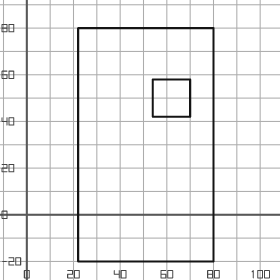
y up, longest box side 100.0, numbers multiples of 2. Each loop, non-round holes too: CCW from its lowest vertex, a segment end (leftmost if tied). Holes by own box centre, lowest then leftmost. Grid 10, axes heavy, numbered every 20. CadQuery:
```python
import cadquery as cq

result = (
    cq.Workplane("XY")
    .moveTo(22.0, -20.0)
    .lineTo(80.0, -20.0)
    .lineTo(80.0, 80.0)
    .lineTo(22.0, 80.0)
    .close()
    .moveTo(54.0, 42.0)
    .lineTo(70.0, 42.0)
    .lineTo(70.0, 58.0)
    .lineTo(54.0, 58.0)
    .close()
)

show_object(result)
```